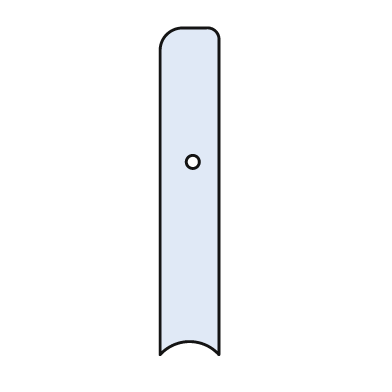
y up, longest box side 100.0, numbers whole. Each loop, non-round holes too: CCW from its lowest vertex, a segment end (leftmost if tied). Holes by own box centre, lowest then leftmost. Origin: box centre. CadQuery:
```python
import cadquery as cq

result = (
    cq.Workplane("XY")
    .moveTo(-9.0, -50.0)
    .threePointArc((0.0, -46.0), (9.0, -50.0))
    .lineTo(9.0, 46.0)
    .threePointArc((8.0, 49.0), (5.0, 50.0))
    .lineTo(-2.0, 50.0)
    .threePointArc((-7.0, 48.0), (-9.0, 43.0))
    .close()
    .moveTo(1.0, 9.0)
    .circle(2.0)
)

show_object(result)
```